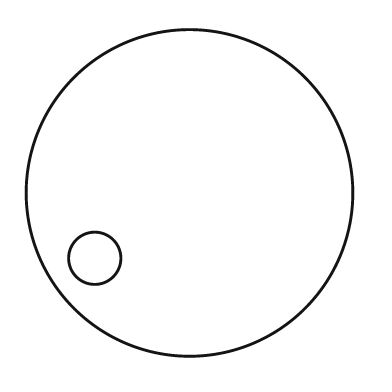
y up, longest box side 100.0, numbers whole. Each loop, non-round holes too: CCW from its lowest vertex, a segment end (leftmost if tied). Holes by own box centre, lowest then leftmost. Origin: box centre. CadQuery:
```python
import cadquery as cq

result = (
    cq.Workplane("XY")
    .moveTo(0.0, 0.0)
    .circle(50.0)
    .moveTo(-29.0, -20.0)
    .circle(8.0)
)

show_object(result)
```